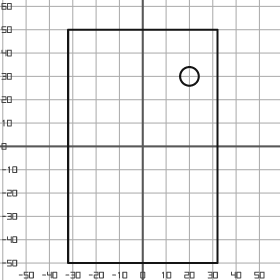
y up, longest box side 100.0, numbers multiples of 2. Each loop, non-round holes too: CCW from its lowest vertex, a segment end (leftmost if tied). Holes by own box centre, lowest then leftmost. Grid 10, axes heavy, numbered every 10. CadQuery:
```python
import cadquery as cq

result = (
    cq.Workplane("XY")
    .moveTo(-32.0, -50.0)
    .lineTo(32.0, -50.0)
    .lineTo(32.0, 50.0)
    .lineTo(-32.0, 50.0)
    .close()
    .moveTo(20.0, 30.0)
    .circle(4.0)
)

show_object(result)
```